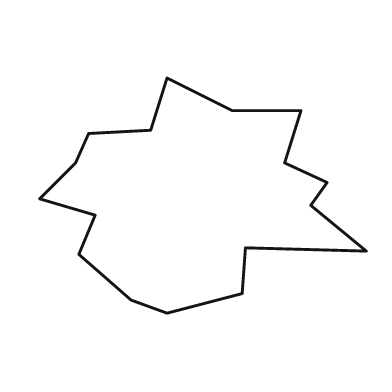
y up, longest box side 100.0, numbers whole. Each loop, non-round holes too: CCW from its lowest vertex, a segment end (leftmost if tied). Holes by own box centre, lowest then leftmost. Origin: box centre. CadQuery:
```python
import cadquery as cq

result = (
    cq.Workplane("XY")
    .moveTo(-11.0, -36.0)
    .lineTo(12.0, -30.0)
    .lineTo(13.0, -16.0)
    .lineTo(50.0, -17.0)
    .lineTo(33.0, -3.0)
    .lineTo(38.0, 4.0)
    .lineTo(25.0, 10.0)
    .lineTo(30.0, 26.0)
    .lineTo(9.0, 26.0)
    .lineTo(-11.0, 36.0)
    .lineTo(-16.0, 20.0)
    .lineTo(-35.0, 19.0)
    .lineTo(-39.0, 10.0)
    .lineTo(-50.0, -1.0)
    .lineTo(-33.0, -6.0)
    .lineTo(-38.0, -18.0)
    .lineTo(-22.0, -32.0)
    .close()
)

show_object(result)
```